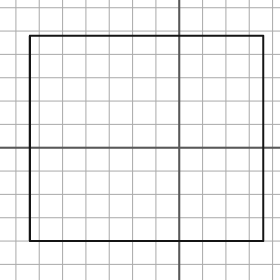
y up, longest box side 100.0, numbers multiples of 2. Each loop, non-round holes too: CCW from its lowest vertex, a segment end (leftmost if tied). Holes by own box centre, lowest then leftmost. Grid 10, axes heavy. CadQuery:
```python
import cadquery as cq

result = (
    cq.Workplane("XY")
    .moveTo(-64.0, -40.0)
    .lineTo(36.0, -40.0)
    .lineTo(36.0, 48.0)
    .lineTo(-64.0, 48.0)
    .close()
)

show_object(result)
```